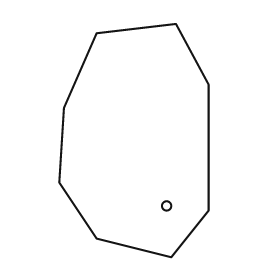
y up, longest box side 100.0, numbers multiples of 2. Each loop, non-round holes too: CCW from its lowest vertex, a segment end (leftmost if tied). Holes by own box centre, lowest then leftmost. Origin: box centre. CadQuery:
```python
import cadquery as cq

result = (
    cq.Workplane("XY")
    .moveTo(16.0, -50.0)
    .lineTo(32.0, -30.0)
    .lineTo(32.0, 24.0)
    .lineTo(18.0, 50.0)
    .lineTo(-16.0, 46.0)
    .lineTo(-30.0, 14.0)
    .lineTo(-32.0, -18.0)
    .lineTo(-16.0, -42.0)
    .close()
    .moveTo(14.0, -28.0)
    .circle(2.0)
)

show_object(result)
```